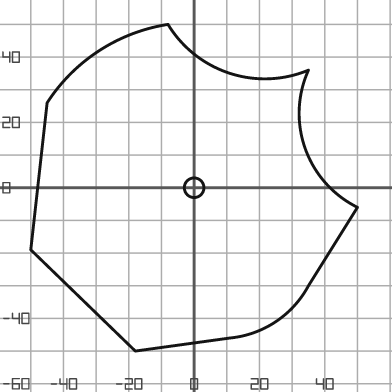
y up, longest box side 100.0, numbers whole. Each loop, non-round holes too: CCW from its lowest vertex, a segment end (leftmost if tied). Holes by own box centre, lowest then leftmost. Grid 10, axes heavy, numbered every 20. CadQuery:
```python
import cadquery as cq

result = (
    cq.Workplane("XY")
    .moveTo(-18.0, -50.0)
    .lineTo(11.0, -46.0)
    .threePointArc((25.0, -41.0), (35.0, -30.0))
    .lineTo(50.0, -6.0)
    .threePointArc((34.0, 12.0), (35.0, 36.0))
    .threePointArc((11.0, 35.0), (-8.0, 50.0))
    .threePointArc((-29.0, 42.0), (-45.0, 26.0))
    .lineTo(-50.0, -19.0)
    .close()
    .moveTo(0.0, 0.0)
    .circle(3.0)
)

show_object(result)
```